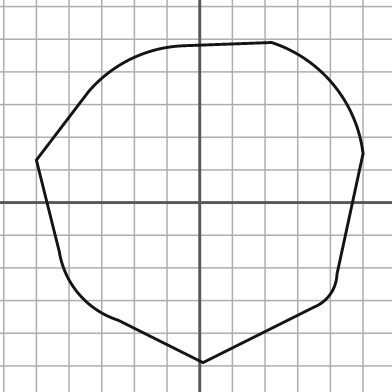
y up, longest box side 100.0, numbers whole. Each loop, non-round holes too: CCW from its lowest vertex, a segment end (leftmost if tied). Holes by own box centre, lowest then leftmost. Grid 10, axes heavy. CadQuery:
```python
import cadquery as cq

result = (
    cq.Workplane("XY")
    .moveTo(1.0, -49.0)
    .lineTo(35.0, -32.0)
    .threePointArc((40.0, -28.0), (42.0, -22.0))
    .lineTo(50.0, 15.0)
    .threePointArc((41.0, 36.0), (22.0, 49.0))
    .lineTo(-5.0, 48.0)
    .threePointArc((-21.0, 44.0), (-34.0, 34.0))
    .lineTo(-50.0, 13.0)
    .lineTo(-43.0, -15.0)
    .threePointArc((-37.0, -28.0), (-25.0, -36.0))
    .close()
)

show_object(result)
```